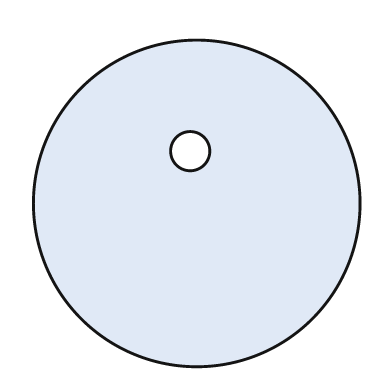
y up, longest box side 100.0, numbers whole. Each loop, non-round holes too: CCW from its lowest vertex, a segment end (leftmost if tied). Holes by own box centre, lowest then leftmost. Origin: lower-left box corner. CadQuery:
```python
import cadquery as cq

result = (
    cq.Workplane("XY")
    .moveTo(50.0, 50.0)
    .circle(50.0)
    .moveTo(48.0, 66.0)
    .circle(6.0)
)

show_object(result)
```